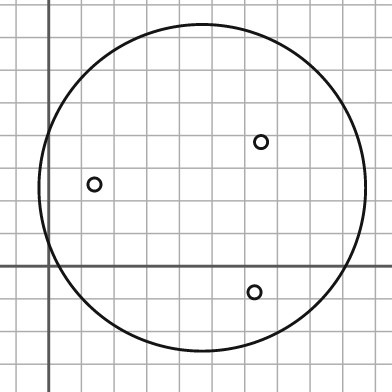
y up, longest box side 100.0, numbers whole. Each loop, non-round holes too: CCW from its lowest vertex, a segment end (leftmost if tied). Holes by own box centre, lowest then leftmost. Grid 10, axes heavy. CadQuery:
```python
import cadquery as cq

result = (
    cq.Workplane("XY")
    .moveTo(47.0, 24.0)
    .circle(50.0)
    .moveTo(63.0, -8.0)
    .circle(2.0)
    .moveTo(14.0, 25.0)
    .circle(2.0)
    .moveTo(65.0, 38.0)
    .circle(2.0)
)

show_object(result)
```